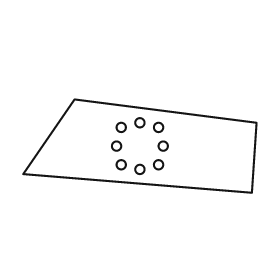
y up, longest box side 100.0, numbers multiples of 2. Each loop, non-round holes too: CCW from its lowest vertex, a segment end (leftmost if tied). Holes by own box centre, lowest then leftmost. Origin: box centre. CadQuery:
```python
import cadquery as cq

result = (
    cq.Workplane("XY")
    .moveTo(48.0, -20.0)
    .lineTo(50.0, 10.0)
    .lineTo(-28.0, 20.0)
    .lineTo(-50.0, -12.0)
    .close()
    .moveTo(0.0, -10.0)
    .circle(2.0)
    .moveTo(-8.0, -8.0)
    .circle(2.0)
    .moveTo(8.0, -8.0)
    .circle(2.0)
    .moveTo(-10.0, 0.0)
    .circle(2.0)
    .moveTo(10.0, 0.0)
    .circle(2.0)
    .moveTo(-8.0, 8.0)
    .circle(2.0)
    .moveTo(8.0, 8.0)
    .circle(2.0)
    .moveTo(0.0, 10.0)
    .circle(2.0)
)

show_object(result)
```